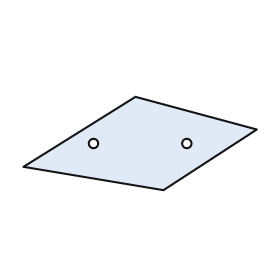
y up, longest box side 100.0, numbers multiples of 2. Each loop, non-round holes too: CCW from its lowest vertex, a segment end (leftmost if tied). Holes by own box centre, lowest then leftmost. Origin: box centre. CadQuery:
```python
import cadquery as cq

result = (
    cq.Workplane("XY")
    .moveTo(10.0, -20.0)
    .lineTo(50.0, 6.0)
    .lineTo(-2.0, 20.0)
    .lineTo(-50.0, -10.0)
    .close()
    .moveTo(-20.0, 0.0)
    .circle(2.0)
    .moveTo(20.0, 0.0)
    .circle(2.0)
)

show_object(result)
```